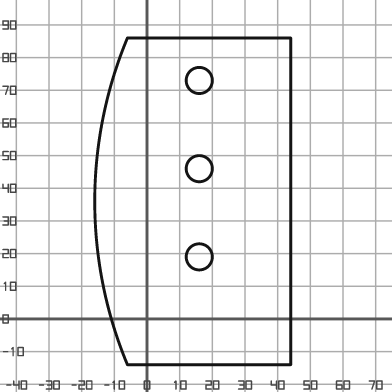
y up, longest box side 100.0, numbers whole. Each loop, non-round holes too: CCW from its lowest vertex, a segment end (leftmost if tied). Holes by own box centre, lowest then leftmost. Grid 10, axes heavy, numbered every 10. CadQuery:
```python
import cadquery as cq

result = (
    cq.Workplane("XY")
    .moveTo(-6.0, -14.0)
    .lineTo(44.0, -14.0)
    .lineTo(44.0, 86.0)
    .lineTo(-6.0, 86.0)
    .threePointArc((-16.0, 36.0), (-6.0, -14.0))
    .close()
    .moveTo(16.0, 19.0)
    .circle(4.0)
    .moveTo(16.0, 46.0)
    .circle(4.0)
    .moveTo(16.0, 73.0)
    .circle(4.0)
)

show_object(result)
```